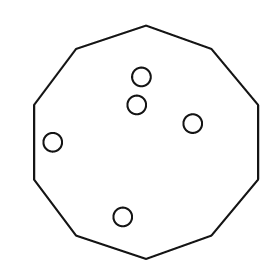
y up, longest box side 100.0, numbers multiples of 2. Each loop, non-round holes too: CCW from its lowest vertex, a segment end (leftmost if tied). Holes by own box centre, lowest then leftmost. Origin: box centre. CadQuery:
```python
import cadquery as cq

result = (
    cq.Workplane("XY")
    .moveTo(0.0, -50.0)
    .lineTo(28.0, -40.0)
    .lineTo(48.0, -16.0)
    .lineTo(48.0, 16.0)
    .lineTo(28.0, 40.0)
    .lineTo(0.0, 50.0)
    .lineTo(-30.0, 40.0)
    .lineTo(-48.0, 16.0)
    .lineTo(-48.0, -16.0)
    .lineTo(-30.0, -40.0)
    .close()
    .moveTo(-10.0, -32.0)
    .circle(4.0)
    .moveTo(-40.0, 0.0)
    .circle(4.0)
    .moveTo(20.0, 8.0)
    .circle(4.0)
    .moveTo(-4.0, 16.0)
    .circle(4.0)
    .moveTo(-2.0, 28.0)
    .circle(4.0)
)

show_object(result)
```